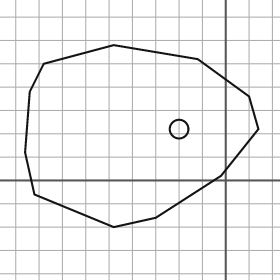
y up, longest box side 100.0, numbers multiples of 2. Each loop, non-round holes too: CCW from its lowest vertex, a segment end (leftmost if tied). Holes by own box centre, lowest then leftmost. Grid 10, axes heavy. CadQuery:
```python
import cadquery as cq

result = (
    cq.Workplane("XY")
    .moveTo(-48.0, -20.0)
    .lineTo(-30.0, -16.0)
    .lineTo(-2.0, 2.0)
    .lineTo(14.0, 22.0)
    .lineTo(10.0, 36.0)
    .lineTo(-12.0, 52.0)
    .lineTo(-48.0, 58.0)
    .lineTo(-78.0, 50.0)
    .lineTo(-84.0, 38.0)
    .lineTo(-86.0, 12.0)
    .lineTo(-82.0, -6.0)
    .close()
    .moveTo(-20.0, 22.0)
    .circle(4.0)
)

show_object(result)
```